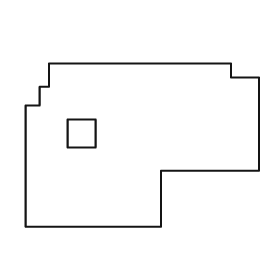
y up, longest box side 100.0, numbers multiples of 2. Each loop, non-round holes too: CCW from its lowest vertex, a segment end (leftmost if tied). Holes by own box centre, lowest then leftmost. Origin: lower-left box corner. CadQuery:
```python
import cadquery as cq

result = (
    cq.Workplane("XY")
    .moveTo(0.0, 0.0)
    .lineTo(58.0, 0.0)
    .lineTo(58.0, 24.0)
    .lineTo(100.0, 24.0)
    .lineTo(100.0, 64.0)
    .lineTo(88.0, 64.0)
    .lineTo(88.0, 70.0)
    .lineTo(10.0, 70.0)
    .lineTo(10.0, 60.0)
    .lineTo(6.0, 60.0)
    .lineTo(6.0, 52.0)
    .lineTo(0.0, 52.0)
    .close()
    .moveTo(18.0, 34.0)
    .lineTo(30.0, 34.0)
    .lineTo(30.0, 46.0)
    .lineTo(18.0, 46.0)
    .close()
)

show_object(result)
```